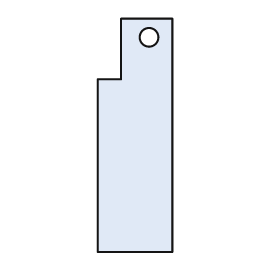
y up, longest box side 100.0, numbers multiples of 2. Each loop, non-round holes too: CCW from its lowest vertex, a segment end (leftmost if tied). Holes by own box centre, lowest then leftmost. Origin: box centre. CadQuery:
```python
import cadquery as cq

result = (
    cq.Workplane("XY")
    .moveTo(-16.0, -50.0)
    .lineTo(16.0, -50.0)
    .lineTo(16.0, 50.0)
    .lineTo(-6.0, 50.0)
    .lineTo(-6.0, 24.0)
    .lineTo(-16.0, 24.0)
    .close()
    .moveTo(6.0, 42.0)
    .circle(4.0)
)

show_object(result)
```